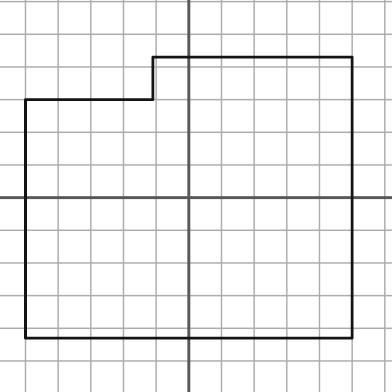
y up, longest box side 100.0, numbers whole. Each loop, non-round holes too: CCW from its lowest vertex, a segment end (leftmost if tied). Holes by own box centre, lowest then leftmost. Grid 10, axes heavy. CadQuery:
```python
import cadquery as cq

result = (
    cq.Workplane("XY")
    .moveTo(-50.0, -43.0)
    .lineTo(50.0, -43.0)
    .lineTo(50.0, 43.0)
    .lineTo(-11.0, 43.0)
    .lineTo(-11.0, 30.0)
    .lineTo(-50.0, 30.0)
    .close()
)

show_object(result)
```